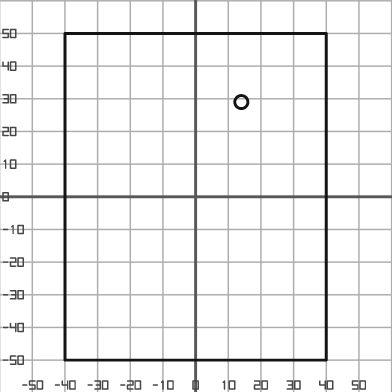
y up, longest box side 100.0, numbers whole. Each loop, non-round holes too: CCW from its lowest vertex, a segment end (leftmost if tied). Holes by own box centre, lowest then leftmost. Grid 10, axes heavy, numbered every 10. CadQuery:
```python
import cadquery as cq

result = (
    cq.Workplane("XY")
    .moveTo(-40.0, -50.0)
    .lineTo(40.0, -50.0)
    .lineTo(40.0, 50.0)
    .lineTo(-40.0, 50.0)
    .close()
    .moveTo(14.0, 29.0)
    .circle(2.0)
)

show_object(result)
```